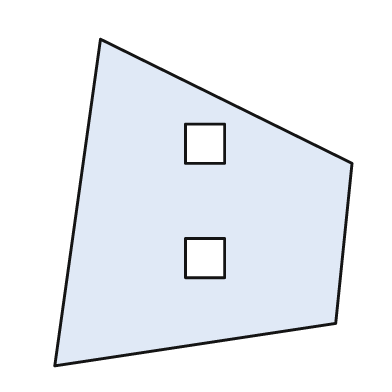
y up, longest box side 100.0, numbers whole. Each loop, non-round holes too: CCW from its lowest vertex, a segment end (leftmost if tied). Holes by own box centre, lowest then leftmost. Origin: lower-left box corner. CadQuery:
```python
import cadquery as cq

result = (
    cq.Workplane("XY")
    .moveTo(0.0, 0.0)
    .lineTo(86.0, 13.0)
    .lineTo(91.0, 62.0)
    .lineTo(14.0, 100.0)
    .close()
    .moveTo(40.0, 27.0)
    .lineTo(52.0, 27.0)
    .lineTo(52.0, 39.0)
    .lineTo(40.0, 39.0)
    .close()
    .moveTo(40.0, 62.0)
    .lineTo(52.0, 62.0)
    .lineTo(52.0, 74.0)
    .lineTo(40.0, 74.0)
    .close()
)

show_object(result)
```